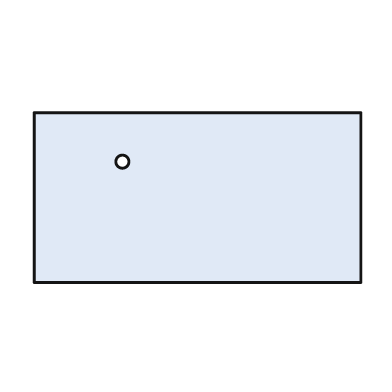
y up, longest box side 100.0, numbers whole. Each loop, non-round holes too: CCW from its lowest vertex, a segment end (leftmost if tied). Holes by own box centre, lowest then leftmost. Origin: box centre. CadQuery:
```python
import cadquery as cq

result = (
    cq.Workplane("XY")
    .moveTo(-50.0, -26.0)
    .lineTo(50.0, -26.0)
    .lineTo(50.0, 26.0)
    .lineTo(-50.0, 26.0)
    .close()
    .moveTo(-23.0, 11.0)
    .circle(2.0)
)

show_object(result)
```